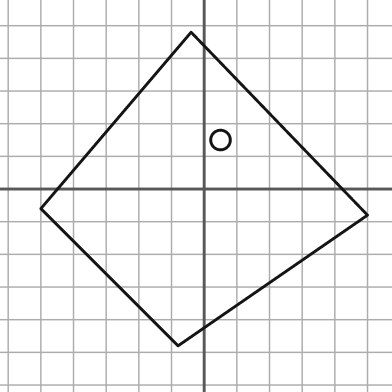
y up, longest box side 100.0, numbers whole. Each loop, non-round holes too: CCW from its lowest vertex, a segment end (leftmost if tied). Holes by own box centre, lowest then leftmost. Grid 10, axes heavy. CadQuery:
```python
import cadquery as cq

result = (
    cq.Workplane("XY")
    .moveTo(-8.0, -48.0)
    .lineTo(50.0, -8.0)
    .lineTo(-4.0, 48.0)
    .lineTo(-50.0, -6.0)
    .close()
    .moveTo(5.0, 15.0)
    .circle(3.0)
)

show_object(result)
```